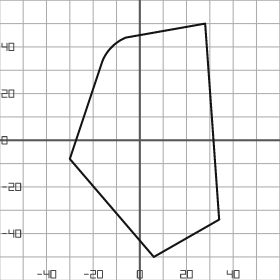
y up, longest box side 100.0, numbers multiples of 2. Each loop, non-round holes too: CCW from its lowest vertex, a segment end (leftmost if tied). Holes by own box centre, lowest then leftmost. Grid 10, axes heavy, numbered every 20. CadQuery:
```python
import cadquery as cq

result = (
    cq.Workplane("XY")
    .moveTo(6.0, -50.0)
    .lineTo(34.0, -34.0)
    .lineTo(28.0, 50.0)
    .lineTo(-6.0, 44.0)
    .threePointArc((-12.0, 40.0), (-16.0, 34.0))
    .lineTo(-30.0, -8.0)
    .close()
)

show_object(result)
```